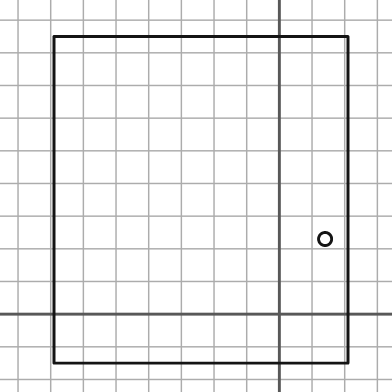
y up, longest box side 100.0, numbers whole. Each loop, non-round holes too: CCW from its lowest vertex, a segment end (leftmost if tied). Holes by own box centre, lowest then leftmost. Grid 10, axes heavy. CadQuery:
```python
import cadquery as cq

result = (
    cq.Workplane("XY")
    .moveTo(-69.0, -15.0)
    .lineTo(21.0, -15.0)
    .lineTo(21.0, 85.0)
    .lineTo(-69.0, 85.0)
    .close()
    .moveTo(14.0, 23.0)
    .circle(2.0)
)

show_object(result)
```